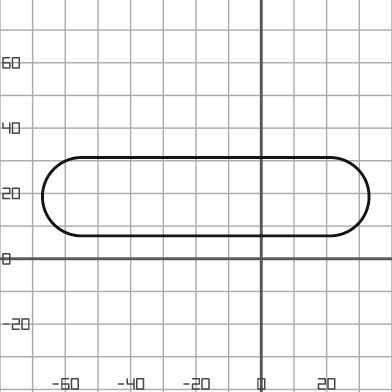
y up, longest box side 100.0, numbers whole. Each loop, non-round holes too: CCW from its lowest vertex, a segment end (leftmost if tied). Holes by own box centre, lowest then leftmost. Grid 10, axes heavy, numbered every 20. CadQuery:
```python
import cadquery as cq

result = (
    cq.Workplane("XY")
    .moveTo(-55.0, 7.0)
    .lineTo(21.0, 7.0)
    .threePointArc((33.0, 19.0), (21.0, 31.0))
    .lineTo(-55.0, 31.0)
    .threePointArc((-67.0, 19.0), (-55.0, 7.0))
    .close()
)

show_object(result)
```